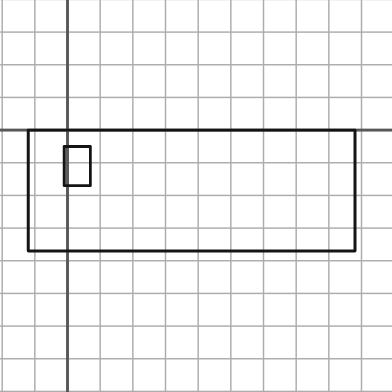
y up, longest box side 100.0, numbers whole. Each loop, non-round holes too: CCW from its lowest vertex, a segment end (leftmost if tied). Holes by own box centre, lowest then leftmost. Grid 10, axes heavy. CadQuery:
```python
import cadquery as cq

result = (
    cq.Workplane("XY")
    .moveTo(-12.0, -37.0)
    .lineTo(88.0, -37.0)
    .lineTo(88.0, 0.0)
    .lineTo(-12.0, 0.0)
    .close()
    .moveTo(-1.0, -17.0)
    .lineTo(7.0, -17.0)
    .lineTo(7.0, -5.0)
    .lineTo(-1.0, -5.0)
    .close()
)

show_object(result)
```